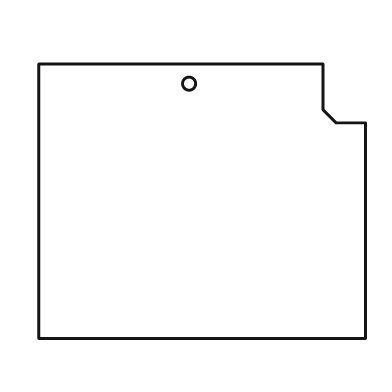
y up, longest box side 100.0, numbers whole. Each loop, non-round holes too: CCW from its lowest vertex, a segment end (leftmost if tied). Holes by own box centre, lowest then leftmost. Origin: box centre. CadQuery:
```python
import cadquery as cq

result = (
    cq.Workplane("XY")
    .moveTo(-50.0, -42.0)
    .lineTo(50.0, -42.0)
    .lineTo(50.0, 24.0)
    .lineTo(41.0, 24.0)
    .lineTo(37.0, 28.0)
    .lineTo(37.0, 42.0)
    .lineTo(-50.0, 42.0)
    .close()
    .moveTo(-4.0, 36.0)
    .circle(2.0)
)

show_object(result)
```